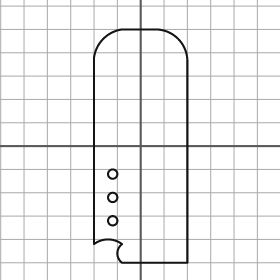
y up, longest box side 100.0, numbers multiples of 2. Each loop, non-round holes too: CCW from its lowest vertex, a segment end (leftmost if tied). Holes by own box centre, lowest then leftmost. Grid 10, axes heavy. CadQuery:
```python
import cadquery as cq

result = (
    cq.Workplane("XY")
    .moveTo(-8.0, -50.0)
    .lineTo(20.0, -50.0)
    .lineTo(20.0, 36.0)
    .threePointArc((16.0, 46.0), (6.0, 50.0))
    .lineTo(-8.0, 50.0)
    .threePointArc((-16.0, 46.0), (-20.0, 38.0))
    .lineTo(-20.0, -42.0)
    .threePointArc((-14.0, -40.0), (-8.0, -42.0))
    .threePointArc((-10.0, -46.0), (-8.0, -50.0))
    .close()
    .moveTo(-12.0, -32.0)
    .circle(2.0)
    .moveTo(-12.0, -22.0)
    .circle(2.0)
    .moveTo(-12.0, -12.0)
    .circle(2.0)
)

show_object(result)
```